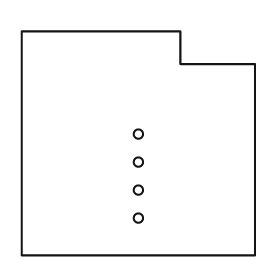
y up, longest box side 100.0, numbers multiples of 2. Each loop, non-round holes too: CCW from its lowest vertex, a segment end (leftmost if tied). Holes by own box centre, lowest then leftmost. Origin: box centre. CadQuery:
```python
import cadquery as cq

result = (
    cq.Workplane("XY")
    .moveTo(-50.0, -48.0)
    .lineTo(50.0, -48.0)
    .lineTo(50.0, 34.0)
    .lineTo(18.0, 34.0)
    .lineTo(18.0, 48.0)
    .lineTo(-50.0, 48.0)
    .close()
    .moveTo(0.0, -32.0)
    .circle(2.0)
    .moveTo(0.0, -20.0)
    .circle(2.0)
    .moveTo(0.0, -8.0)
    .circle(2.0)
    .moveTo(0.0, 4.0)
    .circle(2.0)
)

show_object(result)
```